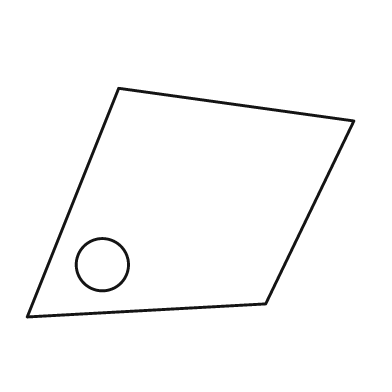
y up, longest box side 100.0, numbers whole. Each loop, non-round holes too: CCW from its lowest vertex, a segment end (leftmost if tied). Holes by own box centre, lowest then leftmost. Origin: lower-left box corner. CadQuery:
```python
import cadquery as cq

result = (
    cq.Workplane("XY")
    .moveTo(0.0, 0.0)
    .lineTo(73.0, 4.0)
    .lineTo(100.0, 60.0)
    .lineTo(28.0, 70.0)
    .close()
    .moveTo(23.0, 16.0)
    .circle(8.0)
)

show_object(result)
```